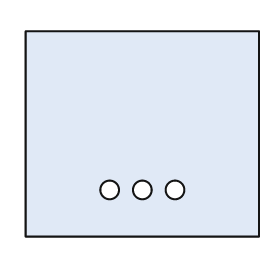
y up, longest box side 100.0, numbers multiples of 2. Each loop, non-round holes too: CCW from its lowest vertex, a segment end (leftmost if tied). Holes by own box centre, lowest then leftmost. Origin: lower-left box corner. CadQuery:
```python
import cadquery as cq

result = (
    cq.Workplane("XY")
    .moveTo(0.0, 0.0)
    .lineTo(100.0, 0.0)
    .lineTo(100.0, 88.0)
    .lineTo(0.0, 88.0)
    .close()
    .moveTo(36.0, 20.0)
    .circle(4.0)
    .moveTo(50.0, 20.0)
    .circle(4.0)
    .moveTo(64.0, 20.0)
    .circle(4.0)
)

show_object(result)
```